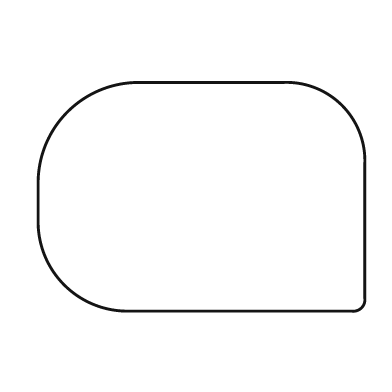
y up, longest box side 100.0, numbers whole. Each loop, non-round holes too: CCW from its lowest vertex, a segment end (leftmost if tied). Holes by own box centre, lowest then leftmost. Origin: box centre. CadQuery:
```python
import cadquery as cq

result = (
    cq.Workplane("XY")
    .moveTo(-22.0, -35.0)
    .lineTo(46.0, -35.0)
    .threePointArc((49.0, -34.0), (50.0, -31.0))
    .lineTo(50.0, 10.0)
    .threePointArc((43.0, 28.0), (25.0, 35.0))
    .lineTo(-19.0, 35.0)
    .threePointArc((-41.0, 26.0), (-50.0, 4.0))
    .lineTo(-50.0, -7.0)
    .threePointArc((-42.0, -27.0), (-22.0, -35.0))
    .close()
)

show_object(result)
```